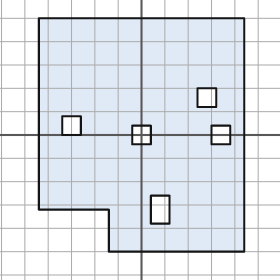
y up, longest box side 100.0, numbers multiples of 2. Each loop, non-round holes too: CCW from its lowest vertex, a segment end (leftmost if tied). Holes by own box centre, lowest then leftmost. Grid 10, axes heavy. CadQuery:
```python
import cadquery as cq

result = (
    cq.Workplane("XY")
    .moveTo(-14.0, -50.0)
    .lineTo(44.0, -50.0)
    .lineTo(44.0, 50.0)
    .lineTo(-44.0, 50.0)
    .lineTo(-44.0, -32.0)
    .lineTo(-14.0, -32.0)
    .close()
    .moveTo(4.0, -38.0)
    .lineTo(12.0, -38.0)
    .lineTo(12.0, -26.0)
    .lineTo(4.0, -26.0)
    .close()
    .moveTo(-4.0, -4.0)
    .lineTo(4.0, -4.0)
    .lineTo(4.0, 4.0)
    .lineTo(-4.0, 4.0)
    .close()
    .moveTo(30.0, -4.0)
    .lineTo(38.0, -4.0)
    .lineTo(38.0, 4.0)
    .lineTo(30.0, 4.0)
    .close()
    .moveTo(-34.0, 0.0)
    .lineTo(-26.0, 0.0)
    .lineTo(-26.0, 8.0)
    .lineTo(-34.0, 8.0)
    .close()
    .moveTo(24.0, 12.0)
    .lineTo(32.0, 12.0)
    .lineTo(32.0, 20.0)
    .lineTo(24.0, 20.0)
    .close()
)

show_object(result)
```